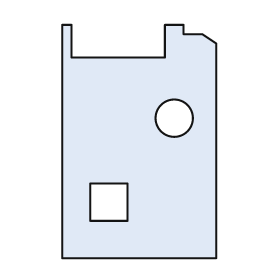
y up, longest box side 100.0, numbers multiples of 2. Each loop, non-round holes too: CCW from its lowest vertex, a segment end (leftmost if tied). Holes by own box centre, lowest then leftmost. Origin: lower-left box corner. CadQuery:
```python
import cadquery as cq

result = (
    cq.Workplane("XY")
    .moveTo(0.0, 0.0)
    .lineTo(66.0, 0.0)
    .lineTo(66.0, 92.0)
    .lineTo(60.0, 96.0)
    .lineTo(52.0, 96.0)
    .lineTo(52.0, 100.0)
    .lineTo(44.0, 100.0)
    .lineTo(44.0, 86.0)
    .lineTo(4.0, 86.0)
    .lineTo(4.0, 100.0)
    .lineTo(0.0, 100.0)
    .close()
    .moveTo(12.0, 16.0)
    .lineTo(28.0, 16.0)
    .lineTo(28.0, 32.0)
    .lineTo(12.0, 32.0)
    .close()
    .moveTo(48.0, 60.0)
    .circle(8.0)
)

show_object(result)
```